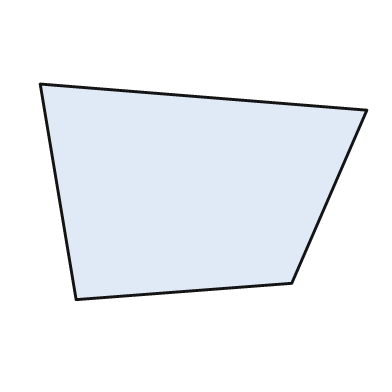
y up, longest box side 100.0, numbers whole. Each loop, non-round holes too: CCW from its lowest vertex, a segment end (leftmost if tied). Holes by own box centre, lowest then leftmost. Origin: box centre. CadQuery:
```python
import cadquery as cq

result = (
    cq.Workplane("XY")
    .moveTo(-39.0, -33.0)
    .lineTo(27.0, -28.0)
    .lineTo(50.0, 25.0)
    .lineTo(-50.0, 33.0)
    .close()
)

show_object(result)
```